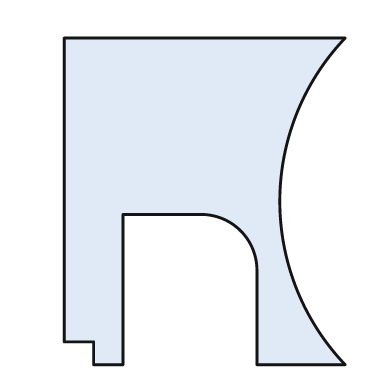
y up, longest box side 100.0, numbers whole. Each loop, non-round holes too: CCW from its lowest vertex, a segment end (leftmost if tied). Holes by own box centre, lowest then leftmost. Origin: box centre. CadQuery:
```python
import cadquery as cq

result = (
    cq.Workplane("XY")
    .moveTo(-34.0, -50.0)
    .lineTo(-25.0, -50.0)
    .lineTo(-25.0, -4.0)
    .lineTo(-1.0, -4.0)
    .threePointArc((11.0, -9.0), (16.0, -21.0))
    .lineTo(16.0, -50.0)
    .lineTo(43.0, -50.0)
    .threePointArc((23.0, 0.0), (43.0, 50.0))
    .lineTo(-43.0, 50.0)
    .lineTo(-43.0, -43.0)
    .lineTo(-34.0, -43.0)
    .close()
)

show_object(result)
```